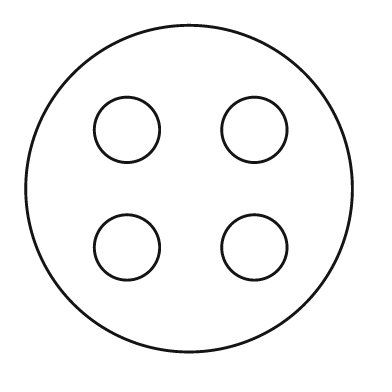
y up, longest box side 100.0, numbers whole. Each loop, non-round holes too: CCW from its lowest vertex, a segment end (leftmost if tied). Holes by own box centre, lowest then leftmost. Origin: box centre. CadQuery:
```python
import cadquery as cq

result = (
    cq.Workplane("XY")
    .moveTo(0.0, 0.0)
    .circle(50.0)
    .moveTo(-19.0, -18.0)
    .circle(10.0)
    .moveTo(20.0, -18.0)
    .circle(10.0)
    .moveTo(-19.0, 18.0)
    .circle(10.0)
    .moveTo(20.0, 18.0)
    .circle(10.0)
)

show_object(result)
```